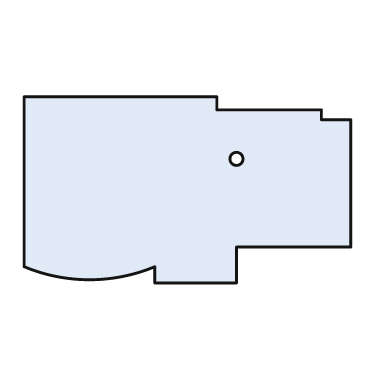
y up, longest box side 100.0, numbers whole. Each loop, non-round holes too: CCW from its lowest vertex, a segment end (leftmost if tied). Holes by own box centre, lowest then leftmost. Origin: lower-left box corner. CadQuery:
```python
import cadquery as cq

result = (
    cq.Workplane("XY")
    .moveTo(40.0, 0.0)
    .lineTo(65.0, 0.0)
    .lineTo(65.0, 11.0)
    .lineTo(100.0, 11.0)
    .lineTo(100.0, 50.0)
    .lineTo(91.0, 50.0)
    .lineTo(91.0, 53.0)
    .lineTo(59.0, 53.0)
    .lineTo(59.0, 57.0)
    .lineTo(0.0, 57.0)
    .lineTo(0.0, 5.0)
    .threePointArc((20.0, 1.0), (40.0, 5.0))
    .close()
    .moveTo(65.0, 38.0)
    .circle(2.0)
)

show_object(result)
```